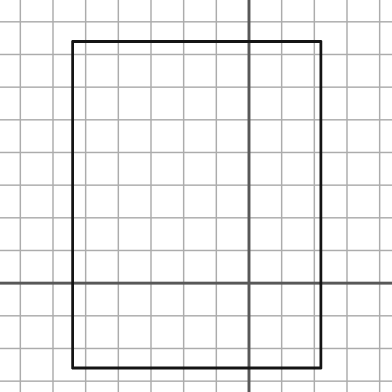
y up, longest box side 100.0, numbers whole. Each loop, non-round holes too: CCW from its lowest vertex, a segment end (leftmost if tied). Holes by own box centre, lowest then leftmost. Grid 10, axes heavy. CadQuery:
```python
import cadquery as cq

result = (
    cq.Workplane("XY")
    .moveTo(-54.0, -26.0)
    .lineTo(22.0, -26.0)
    .lineTo(22.0, 74.0)
    .lineTo(-54.0, 74.0)
    .close()
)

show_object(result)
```